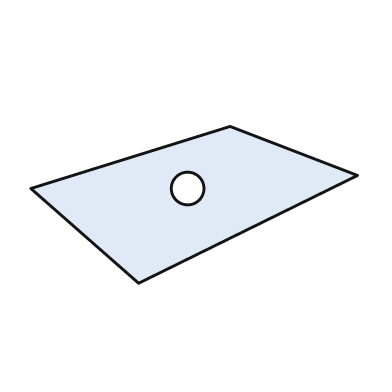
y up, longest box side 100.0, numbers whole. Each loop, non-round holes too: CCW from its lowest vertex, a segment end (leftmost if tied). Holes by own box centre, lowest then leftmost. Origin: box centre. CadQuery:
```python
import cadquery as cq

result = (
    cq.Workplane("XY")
    .moveTo(-17.0, -24.0)
    .lineTo(50.0, 9.0)
    .lineTo(11.0, 24.0)
    .lineTo(-50.0, 5.0)
    .close()
    .moveTo(-2.0, 5.0)
    .circle(5.0)
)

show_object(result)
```